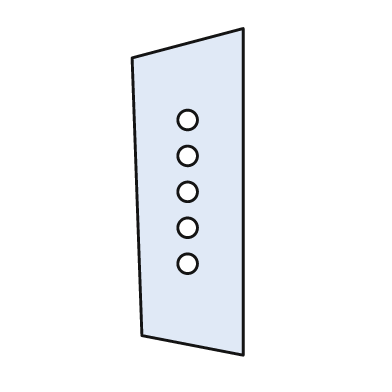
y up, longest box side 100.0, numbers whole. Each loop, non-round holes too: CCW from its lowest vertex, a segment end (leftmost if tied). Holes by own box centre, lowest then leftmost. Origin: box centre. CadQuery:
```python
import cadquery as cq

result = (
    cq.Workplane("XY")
    .moveTo(17.0, -50.0)
    .lineTo(17.0, 50.0)
    .lineTo(-17.0, 41.0)
    .lineTo(-14.0, -44.0)
    .close()
    .moveTo(0.0, -22.0)
    .circle(3.0)
    .moveTo(0.0, -11.0)
    .circle(3.0)
    .moveTo(0.0, 0.0)
    .circle(3.0)
    .moveTo(0.0, 11.0)
    .circle(3.0)
    .moveTo(0.0, 22.0)
    .circle(3.0)
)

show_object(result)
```